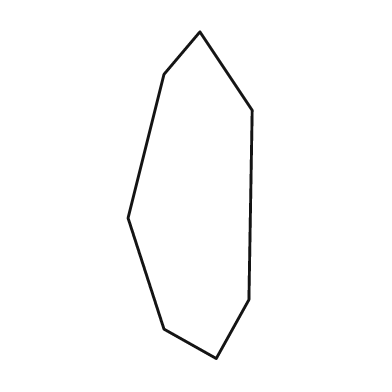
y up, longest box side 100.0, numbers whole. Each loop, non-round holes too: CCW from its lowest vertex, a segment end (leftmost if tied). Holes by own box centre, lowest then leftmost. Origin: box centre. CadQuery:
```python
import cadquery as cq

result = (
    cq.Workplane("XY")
    .moveTo(8.0, -50.0)
    .lineTo(18.0, -32.0)
    .lineTo(19.0, 26.0)
    .lineTo(3.0, 50.0)
    .lineTo(-8.0, 37.0)
    .lineTo(-19.0, -7.0)
    .lineTo(-8.0, -41.0)
    .close()
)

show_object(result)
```